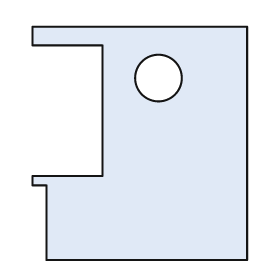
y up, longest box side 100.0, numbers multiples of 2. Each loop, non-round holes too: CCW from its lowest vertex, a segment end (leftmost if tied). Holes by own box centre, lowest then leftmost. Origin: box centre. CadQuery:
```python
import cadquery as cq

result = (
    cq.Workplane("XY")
    .moveTo(-40.0, -50.0)
    .lineTo(46.0, -50.0)
    .lineTo(46.0, 50.0)
    .lineTo(-46.0, 50.0)
    .lineTo(-46.0, 42.0)
    .lineTo(-16.0, 42.0)
    .lineTo(-16.0, -14.0)
    .lineTo(-46.0, -14.0)
    .lineTo(-46.0, -18.0)
    .lineTo(-40.0, -18.0)
    .close()
    .moveTo(8.0, 28.0)
    .circle(10.0)
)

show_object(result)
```